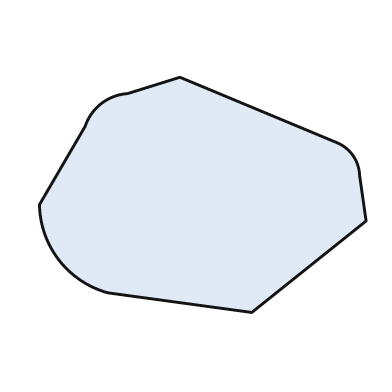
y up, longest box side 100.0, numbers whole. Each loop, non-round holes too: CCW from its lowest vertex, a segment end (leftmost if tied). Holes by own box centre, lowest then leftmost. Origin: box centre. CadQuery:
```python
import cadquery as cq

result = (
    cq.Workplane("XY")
    .moveTo(15.0, -36.0)
    .lineTo(50.0, -8.0)
    .lineTo(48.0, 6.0)
    .threePointArc((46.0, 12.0), (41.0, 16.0))
    .lineTo(-7.0, 36.0)
    .lineTo(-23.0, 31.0)
    .threePointArc((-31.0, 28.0), (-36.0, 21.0))
    .lineTo(-50.0, -3.0)
    .threePointArc((-44.0, -20.0), (-29.0, -30.0))
    .close()
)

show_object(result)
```